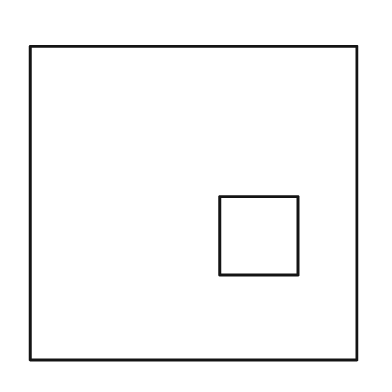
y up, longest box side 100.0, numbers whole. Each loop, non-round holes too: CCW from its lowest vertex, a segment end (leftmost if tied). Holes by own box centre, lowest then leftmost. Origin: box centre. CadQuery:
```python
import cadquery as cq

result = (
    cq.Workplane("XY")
    .moveTo(-50.0, -48.0)
    .lineTo(50.0, -48.0)
    .lineTo(50.0, 48.0)
    .lineTo(-50.0, 48.0)
    .close()
    .moveTo(8.0, -22.0)
    .lineTo(32.0, -22.0)
    .lineTo(32.0, 2.0)
    .lineTo(8.0, 2.0)
    .close()
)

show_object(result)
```